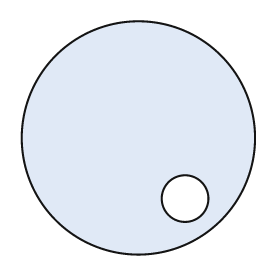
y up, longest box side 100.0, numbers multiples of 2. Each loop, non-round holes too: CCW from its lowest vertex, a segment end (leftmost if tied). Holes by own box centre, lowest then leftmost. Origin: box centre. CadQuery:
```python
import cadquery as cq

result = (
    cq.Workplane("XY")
    .moveTo(0.0, 0.0)
    .circle(50.0)
    .moveTo(20.0, -26.0)
    .circle(10.0)
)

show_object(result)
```